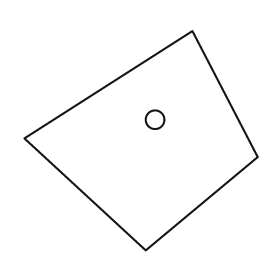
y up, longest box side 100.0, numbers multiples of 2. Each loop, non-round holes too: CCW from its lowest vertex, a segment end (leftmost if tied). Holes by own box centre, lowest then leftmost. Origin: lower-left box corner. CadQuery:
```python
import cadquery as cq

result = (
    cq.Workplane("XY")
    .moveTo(52.0, 0.0)
    .lineTo(100.0, 40.0)
    .lineTo(72.0, 94.0)
    .lineTo(0.0, 48.0)
    .close()
    .moveTo(56.0, 56.0)
    .circle(4.0)
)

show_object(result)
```